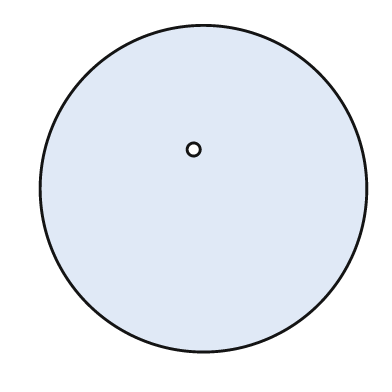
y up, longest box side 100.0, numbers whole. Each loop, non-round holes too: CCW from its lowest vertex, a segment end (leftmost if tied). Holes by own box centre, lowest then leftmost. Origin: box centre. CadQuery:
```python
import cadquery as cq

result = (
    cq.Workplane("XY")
    .moveTo(0.0, 0.0)
    .circle(50.0)
    .moveTo(-3.0, 12.0)
    .circle(2.0)
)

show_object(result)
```